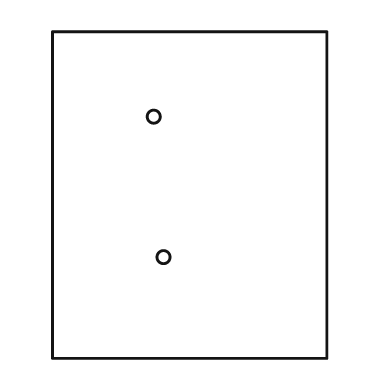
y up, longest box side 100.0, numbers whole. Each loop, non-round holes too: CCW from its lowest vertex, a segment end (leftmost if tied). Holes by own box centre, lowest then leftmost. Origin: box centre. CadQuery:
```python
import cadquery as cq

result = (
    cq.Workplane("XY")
    .moveTo(-42.0, -50.0)
    .lineTo(42.0, -50.0)
    .lineTo(42.0, 50.0)
    .lineTo(-42.0, 50.0)
    .close()
    .moveTo(-8.0, -19.0)
    .circle(2.0)
    .moveTo(-11.0, 24.0)
    .circle(2.0)
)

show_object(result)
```